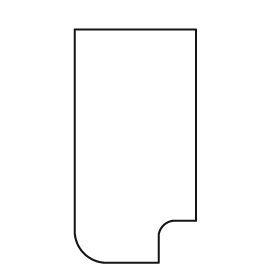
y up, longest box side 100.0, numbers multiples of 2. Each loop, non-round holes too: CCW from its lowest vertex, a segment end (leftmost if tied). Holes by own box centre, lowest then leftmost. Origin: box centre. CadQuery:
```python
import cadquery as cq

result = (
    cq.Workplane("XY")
    .moveTo(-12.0, -50.0)
    .lineTo(10.0, -50.0)
    .lineTo(10.0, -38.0)
    .threePointArc((12.0, -34.0), (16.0, -32.0))
    .lineTo(26.0, -32.0)
    .lineTo(26.0, 50.0)
    .lineTo(-26.0, 50.0)
    .lineTo(-26.0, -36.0)
    .threePointArc((-22.0, -46.0), (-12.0, -50.0))
    .close()
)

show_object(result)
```